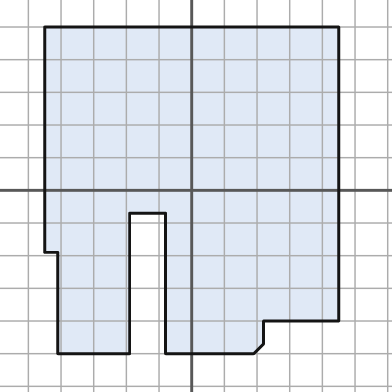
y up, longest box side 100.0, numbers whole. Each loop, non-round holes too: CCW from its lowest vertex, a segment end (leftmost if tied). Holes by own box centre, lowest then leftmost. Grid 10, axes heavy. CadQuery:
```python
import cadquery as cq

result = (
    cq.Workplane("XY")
    .moveTo(-41.0, -50.0)
    .lineTo(-19.0, -50.0)
    .lineTo(-19.0, -7.0)
    .lineTo(-8.0, -7.0)
    .lineTo(-8.0, -50.0)
    .lineTo(19.0, -50.0)
    .lineTo(22.0, -47.0)
    .lineTo(22.0, -40.0)
    .lineTo(45.0, -40.0)
    .lineTo(45.0, 50.0)
    .lineTo(-45.0, 50.0)
    .lineTo(-45.0, -19.0)
    .lineTo(-41.0, -19.0)
    .close()
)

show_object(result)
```